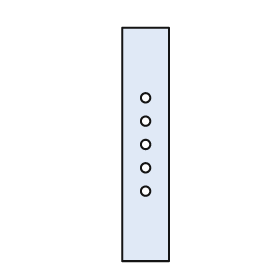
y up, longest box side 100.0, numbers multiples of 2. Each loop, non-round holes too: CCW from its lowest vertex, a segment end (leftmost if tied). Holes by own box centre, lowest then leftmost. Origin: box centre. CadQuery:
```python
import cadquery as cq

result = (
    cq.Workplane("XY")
    .moveTo(-10.0, -50.0)
    .lineTo(10.0, -50.0)
    .lineTo(10.0, 50.0)
    .lineTo(-10.0, 50.0)
    .close()
    .moveTo(0.0, -20.0)
    .circle(2.0)
    .moveTo(0.0, -10.0)
    .circle(2.0)
    .moveTo(0.0, 0.0)
    .circle(2.0)
    .moveTo(0.0, 10.0)
    .circle(2.0)
    .moveTo(0.0, 20.0)
    .circle(2.0)
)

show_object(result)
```